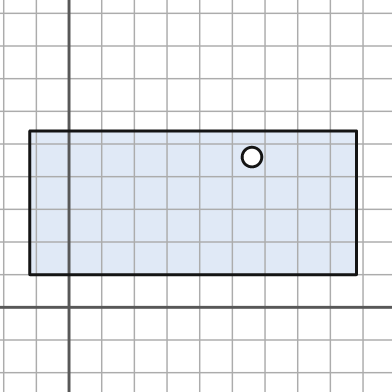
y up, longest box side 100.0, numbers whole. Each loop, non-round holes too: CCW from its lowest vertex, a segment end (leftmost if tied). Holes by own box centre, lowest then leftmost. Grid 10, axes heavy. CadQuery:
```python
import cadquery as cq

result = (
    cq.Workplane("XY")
    .moveTo(-12.0, 10.0)
    .lineTo(88.0, 10.0)
    .lineTo(88.0, 54.0)
    .lineTo(-12.0, 54.0)
    .close()
    .moveTo(56.0, 46.0)
    .circle(3.0)
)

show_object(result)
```